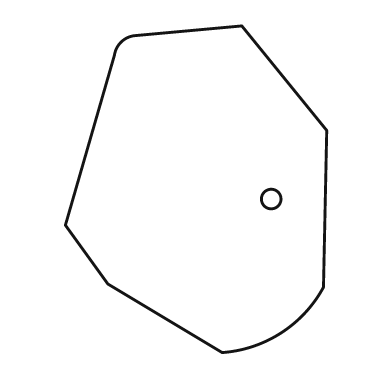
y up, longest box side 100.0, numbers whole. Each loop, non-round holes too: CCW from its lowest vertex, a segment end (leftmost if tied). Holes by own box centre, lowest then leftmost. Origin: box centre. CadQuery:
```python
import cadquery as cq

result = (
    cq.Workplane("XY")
    .moveTo(8.0, -50.0)
    .threePointArc((26.0, -44.0), (39.0, -30.0))
    .lineTo(40.0, 18.0)
    .lineTo(14.0, 50.0)
    .lineTo(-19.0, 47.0)
    .threePointArc((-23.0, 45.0), (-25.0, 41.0))
    .lineTo(-40.0, -11.0)
    .lineTo(-27.0, -29.0)
    .close()
    .moveTo(23.0, -3.0)
    .circle(3.0)
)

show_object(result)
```